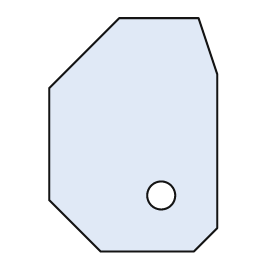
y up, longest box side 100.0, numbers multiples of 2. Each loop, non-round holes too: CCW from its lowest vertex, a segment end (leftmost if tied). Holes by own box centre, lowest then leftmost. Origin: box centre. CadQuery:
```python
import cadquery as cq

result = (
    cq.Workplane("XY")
    .moveTo(-14.0, -50.0)
    .lineTo(26.0, -50.0)
    .lineTo(36.0, -40.0)
    .lineTo(36.0, 26.0)
    .lineTo(28.0, 50.0)
    .lineTo(-6.0, 50.0)
    .lineTo(-36.0, 20.0)
    .lineTo(-36.0, -28.0)
    .close()
    .moveTo(12.0, -26.0)
    .circle(6.0)
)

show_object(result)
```